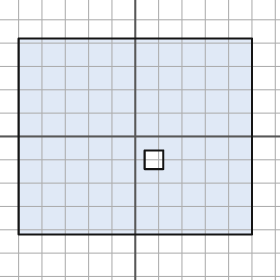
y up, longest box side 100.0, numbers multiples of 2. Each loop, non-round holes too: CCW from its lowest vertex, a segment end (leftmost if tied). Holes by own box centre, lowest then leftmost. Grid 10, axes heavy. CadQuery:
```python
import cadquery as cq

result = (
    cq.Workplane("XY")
    .moveTo(-50.0, -42.0)
    .lineTo(50.0, -42.0)
    .lineTo(50.0, 42.0)
    .lineTo(-50.0, 42.0)
    .close()
    .moveTo(4.0, -14.0)
    .lineTo(12.0, -14.0)
    .lineTo(12.0, -6.0)
    .lineTo(4.0, -6.0)
    .close()
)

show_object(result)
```